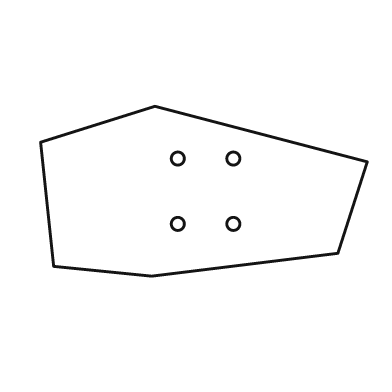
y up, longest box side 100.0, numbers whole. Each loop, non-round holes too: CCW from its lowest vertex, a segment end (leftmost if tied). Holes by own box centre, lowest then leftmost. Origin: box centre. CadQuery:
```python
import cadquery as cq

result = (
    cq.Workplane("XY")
    .moveTo(-16.0, -26.0)
    .lineTo(41.0, -19.0)
    .lineTo(50.0, 9.0)
    .lineTo(-15.0, 26.0)
    .lineTo(-50.0, 15.0)
    .lineTo(-46.0, -23.0)
    .close()
    .moveTo(-8.0, -10.0)
    .circle(2.0)
    .moveTo(9.0, -10.0)
    .circle(2.0)
    .moveTo(-8.0, 10.0)
    .circle(2.0)
    .moveTo(9.0, 10.0)
    .circle(2.0)
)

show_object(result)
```